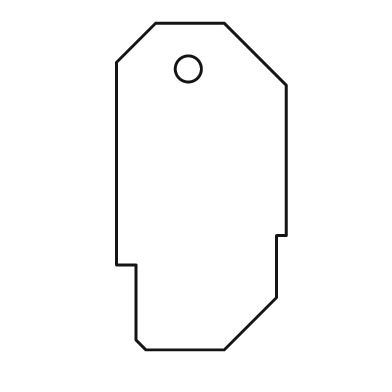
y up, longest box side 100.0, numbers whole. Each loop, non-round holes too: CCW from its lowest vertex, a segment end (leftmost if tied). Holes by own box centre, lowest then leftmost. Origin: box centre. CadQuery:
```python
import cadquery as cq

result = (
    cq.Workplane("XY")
    .moveTo(-17.0, -50.0)
    .lineTo(7.0, -50.0)
    .lineTo(23.0, -34.0)
    .lineTo(23.0, -15.0)
    .lineTo(26.0, -15.0)
    .lineTo(26.0, 31.0)
    .lineTo(7.0, 50.0)
    .lineTo(-14.0, 50.0)
    .lineTo(-26.0, 38.0)
    .lineTo(-26.0, -24.0)
    .lineTo(-20.0, -24.0)
    .lineTo(-20.0, -47.0)
    .close()
    .moveTo(-4.0, 36.0)
    .circle(4.0)
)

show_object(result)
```